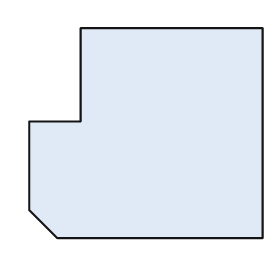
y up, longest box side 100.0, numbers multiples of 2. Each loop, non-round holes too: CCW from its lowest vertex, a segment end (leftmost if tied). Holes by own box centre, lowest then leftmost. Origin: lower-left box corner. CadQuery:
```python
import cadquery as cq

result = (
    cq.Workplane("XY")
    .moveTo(12.0, 0.0)
    .lineTo(100.0, 0.0)
    .lineTo(100.0, 90.0)
    .lineTo(22.0, 90.0)
    .lineTo(22.0, 50.0)
    .lineTo(0.0, 50.0)
    .lineTo(0.0, 12.0)
    .close()
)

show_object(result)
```